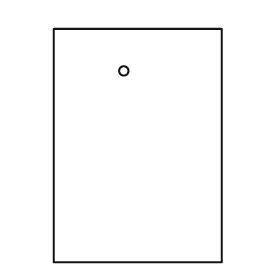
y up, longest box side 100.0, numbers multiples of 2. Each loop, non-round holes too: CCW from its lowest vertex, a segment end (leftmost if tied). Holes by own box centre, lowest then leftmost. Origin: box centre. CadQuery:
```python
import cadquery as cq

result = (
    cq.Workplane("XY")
    .moveTo(-36.0, -50.0)
    .lineTo(36.0, -50.0)
    .lineTo(36.0, 50.0)
    .lineTo(-36.0, 50.0)
    .close()
    .moveTo(-6.0, 32.0)
    .circle(2.0)
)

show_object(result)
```